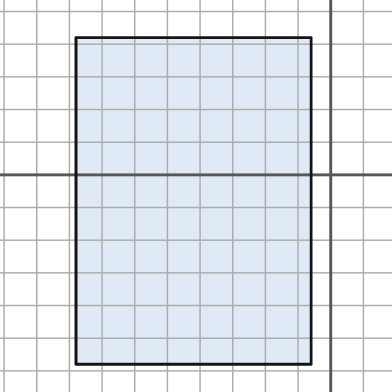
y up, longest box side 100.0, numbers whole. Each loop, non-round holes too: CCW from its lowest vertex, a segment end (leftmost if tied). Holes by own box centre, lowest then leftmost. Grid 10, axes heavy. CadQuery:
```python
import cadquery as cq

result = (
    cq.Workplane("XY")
    .moveTo(-78.0, -58.0)
    .lineTo(-6.0, -58.0)
    .lineTo(-6.0, 42.0)
    .lineTo(-78.0, 42.0)
    .close()
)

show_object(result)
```